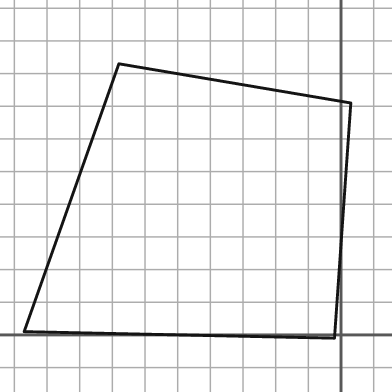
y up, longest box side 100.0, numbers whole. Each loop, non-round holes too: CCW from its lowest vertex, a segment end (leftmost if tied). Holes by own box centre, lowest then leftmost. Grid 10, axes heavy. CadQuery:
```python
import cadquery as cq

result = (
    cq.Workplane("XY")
    .moveTo(-2.0, -1.0)
    .lineTo(3.0, 71.0)
    .lineTo(-68.0, 83.0)
    .lineTo(-97.0, 1.0)
    .close()
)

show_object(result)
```